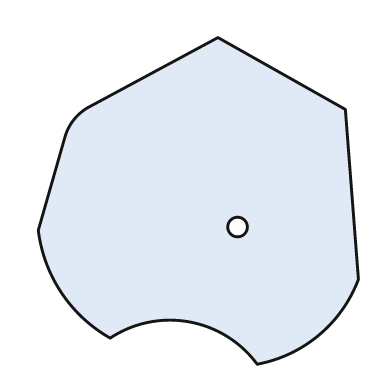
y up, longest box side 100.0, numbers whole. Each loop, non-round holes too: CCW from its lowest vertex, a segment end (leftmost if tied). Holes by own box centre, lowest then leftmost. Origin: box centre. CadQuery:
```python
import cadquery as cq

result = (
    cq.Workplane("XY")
    .moveTo(18.0, -50.0)
    .threePointArc((37.0, -41.0), (49.0, -24.0))
    .lineTo(45.0, 28.0)
    .lineTo(6.0, 50.0)
    .lineTo(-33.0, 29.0)
    .threePointArc((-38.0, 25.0), (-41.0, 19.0))
    .lineTo(-49.0, -9.0)
    .threePointArc((-42.0, -28.0), (-27.0, -42.0))
    .threePointArc((-3.0, -37.0), (18.0, -50.0))
    .close()
    .moveTo(12.0, -8.0)
    .circle(3.0)
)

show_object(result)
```